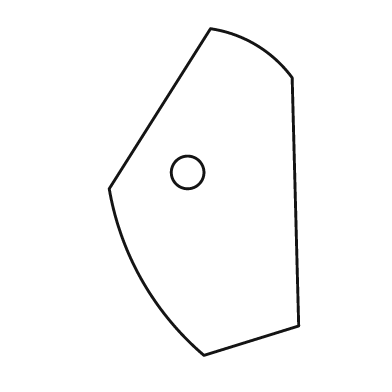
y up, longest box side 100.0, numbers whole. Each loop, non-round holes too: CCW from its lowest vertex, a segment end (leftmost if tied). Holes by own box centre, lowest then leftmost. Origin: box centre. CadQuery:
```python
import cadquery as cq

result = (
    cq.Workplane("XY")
    .moveTo(0.0, -50.0)
    .lineTo(29.0, -41.0)
    .lineTo(27.0, 35.0)
    .threePointArc((16.0, 45.0), (2.0, 50.0))
    .lineTo(-29.0, 1.0)
    .threePointArc((-19.0, -27.0), (0.0, -50.0))
    .close()
    .moveTo(-5.0, 6.0)
    .circle(5.0)
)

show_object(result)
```